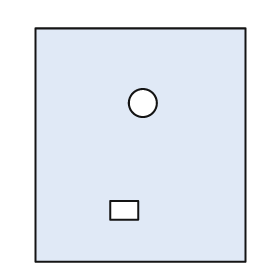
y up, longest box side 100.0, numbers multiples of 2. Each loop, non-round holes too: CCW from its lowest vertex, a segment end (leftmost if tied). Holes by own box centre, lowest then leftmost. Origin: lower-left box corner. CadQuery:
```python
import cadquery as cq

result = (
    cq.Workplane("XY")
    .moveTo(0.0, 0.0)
    .lineTo(90.0, 0.0)
    .lineTo(90.0, 100.0)
    .lineTo(0.0, 100.0)
    .close()
    .moveTo(32.0, 18.0)
    .lineTo(44.0, 18.0)
    .lineTo(44.0, 26.0)
    .lineTo(32.0, 26.0)
    .close()
    .moveTo(46.0, 68.0)
    .circle(6.0)
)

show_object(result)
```